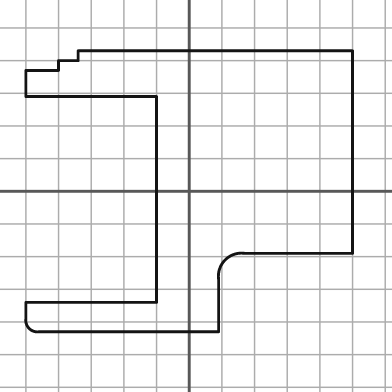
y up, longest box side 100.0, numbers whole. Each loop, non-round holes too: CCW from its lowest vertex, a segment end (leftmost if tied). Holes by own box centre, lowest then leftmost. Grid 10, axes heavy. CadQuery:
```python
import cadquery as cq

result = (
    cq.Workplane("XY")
    .moveTo(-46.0, -43.0)
    .lineTo(9.0, -43.0)
    .lineTo(9.0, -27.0)
    .threePointArc((11.0, -21.0), (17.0, -19.0))
    .lineTo(50.0, -19.0)
    .lineTo(50.0, 43.0)
    .lineTo(-34.0, 43.0)
    .lineTo(-34.0, 40.0)
    .lineTo(-40.0, 40.0)
    .lineTo(-40.0, 37.0)
    .lineTo(-50.0, 37.0)
    .lineTo(-50.0, 29.0)
    .lineTo(-10.0, 29.0)
    .lineTo(-10.0, -34.0)
    .lineTo(-50.0, -34.0)
    .lineTo(-50.0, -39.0)
    .threePointArc((-49.0, -42.0), (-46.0, -43.0))
    .close()
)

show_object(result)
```